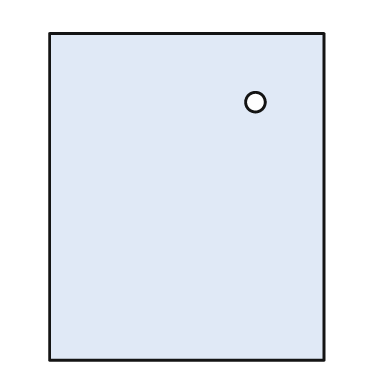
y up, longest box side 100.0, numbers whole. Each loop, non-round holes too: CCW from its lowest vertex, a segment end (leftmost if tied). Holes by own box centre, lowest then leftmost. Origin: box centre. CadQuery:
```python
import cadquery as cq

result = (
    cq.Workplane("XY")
    .moveTo(-42.0, -50.0)
    .lineTo(42.0, -50.0)
    .lineTo(42.0, 50.0)
    .lineTo(-42.0, 50.0)
    .close()
    .moveTo(21.0, 29.0)
    .circle(3.0)
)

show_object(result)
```